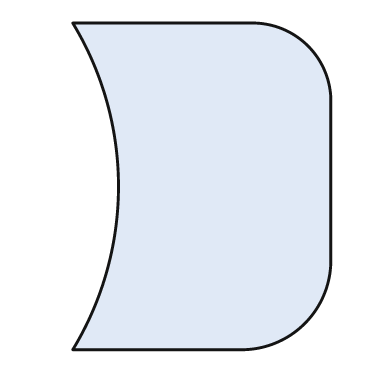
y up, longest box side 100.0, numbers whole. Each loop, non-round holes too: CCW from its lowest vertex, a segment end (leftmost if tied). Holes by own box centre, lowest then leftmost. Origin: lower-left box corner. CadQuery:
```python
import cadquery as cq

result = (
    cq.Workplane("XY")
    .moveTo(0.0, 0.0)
    .lineTo(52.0, 0.0)
    .threePointArc((71.0, 8.0), (79.0, 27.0))
    .lineTo(79.0, 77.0)
    .threePointArc((72.0, 93.0), (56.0, 100.0))
    .lineTo(0.0, 100.0)
    .threePointArc((14.0, 50.0), (0.0, 0.0))
    .close()
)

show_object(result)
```